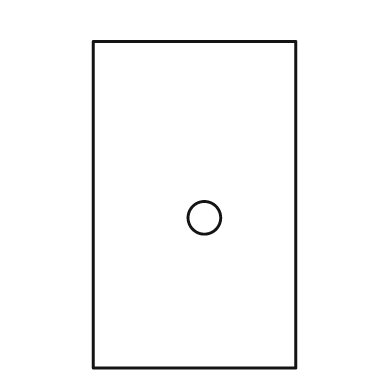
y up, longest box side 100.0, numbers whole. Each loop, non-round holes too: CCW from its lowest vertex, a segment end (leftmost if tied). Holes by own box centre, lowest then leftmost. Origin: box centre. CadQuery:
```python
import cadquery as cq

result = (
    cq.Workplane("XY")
    .moveTo(-31.0, -50.0)
    .lineTo(31.0, -50.0)
    .lineTo(31.0, 50.0)
    .lineTo(-31.0, 50.0)
    .close()
    .moveTo(3.0, -4.0)
    .circle(5.0)
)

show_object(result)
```